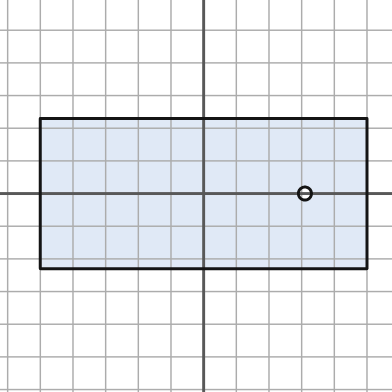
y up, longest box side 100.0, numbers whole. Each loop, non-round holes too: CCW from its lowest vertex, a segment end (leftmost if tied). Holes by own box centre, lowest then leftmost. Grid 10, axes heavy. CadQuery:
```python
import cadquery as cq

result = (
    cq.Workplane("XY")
    .moveTo(-50.0, -23.0)
    .lineTo(50.0, -23.0)
    .lineTo(50.0, 23.0)
    .lineTo(-50.0, 23.0)
    .close()
    .moveTo(31.0, 0.0)
    .circle(2.0)
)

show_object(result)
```